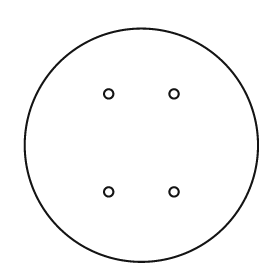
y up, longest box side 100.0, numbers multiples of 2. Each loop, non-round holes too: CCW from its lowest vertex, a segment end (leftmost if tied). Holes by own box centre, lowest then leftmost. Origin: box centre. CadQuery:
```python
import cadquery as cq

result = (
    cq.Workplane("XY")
    .moveTo(0.0, 0.0)
    .circle(50.0)
    .moveTo(-14.0, -20.0)
    .circle(2.0)
    .moveTo(14.0, -20.0)
    .circle(2.0)
    .moveTo(-14.0, 22.0)
    .circle(2.0)
    .moveTo(14.0, 22.0)
    .circle(2.0)
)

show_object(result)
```